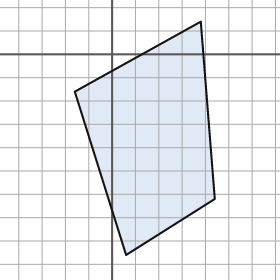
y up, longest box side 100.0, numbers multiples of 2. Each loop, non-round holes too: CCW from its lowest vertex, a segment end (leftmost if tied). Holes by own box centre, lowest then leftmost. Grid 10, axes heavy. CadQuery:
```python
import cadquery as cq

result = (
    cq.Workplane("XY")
    .moveTo(6.0, -86.0)
    .lineTo(44.0, -62.0)
    .lineTo(38.0, 14.0)
    .lineTo(-16.0, -16.0)
    .close()
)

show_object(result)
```